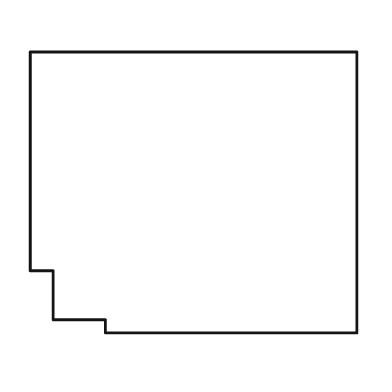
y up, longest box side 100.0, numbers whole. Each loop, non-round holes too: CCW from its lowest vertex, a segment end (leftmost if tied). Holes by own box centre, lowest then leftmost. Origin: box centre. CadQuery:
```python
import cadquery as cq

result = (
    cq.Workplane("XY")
    .moveTo(-27.0, -43.0)
    .lineTo(50.0, -43.0)
    .lineTo(50.0, 43.0)
    .lineTo(-50.0, 43.0)
    .lineTo(-50.0, -24.0)
    .lineTo(-43.0, -24.0)
    .lineTo(-43.0, -39.0)
    .lineTo(-27.0, -39.0)
    .close()
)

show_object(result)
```